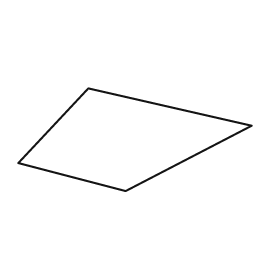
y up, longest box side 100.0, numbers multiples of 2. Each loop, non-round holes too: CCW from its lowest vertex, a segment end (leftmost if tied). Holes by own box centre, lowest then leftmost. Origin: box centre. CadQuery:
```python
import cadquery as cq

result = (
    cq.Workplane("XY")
    .moveTo(-4.0, -22.0)
    .lineTo(50.0, 6.0)
    .lineTo(-20.0, 22.0)
    .lineTo(-50.0, -10.0)
    .close()
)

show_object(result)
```